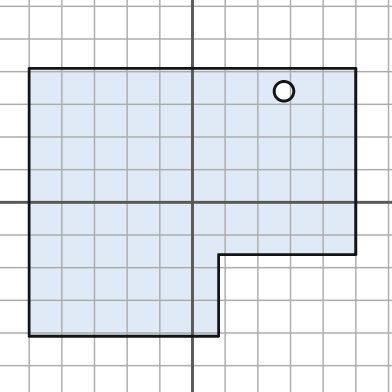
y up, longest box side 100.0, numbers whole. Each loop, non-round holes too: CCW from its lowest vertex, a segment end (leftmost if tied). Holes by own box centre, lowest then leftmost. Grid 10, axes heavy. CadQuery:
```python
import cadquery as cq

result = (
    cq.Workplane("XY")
    .moveTo(-50.0, -41.0)
    .lineTo(8.0, -41.0)
    .lineTo(8.0, -16.0)
    .lineTo(50.0, -16.0)
    .lineTo(50.0, 41.0)
    .lineTo(-50.0, 41.0)
    .close()
    .moveTo(28.0, 34.0)
    .circle(3.0)
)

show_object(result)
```